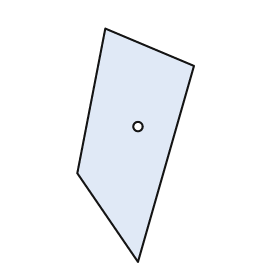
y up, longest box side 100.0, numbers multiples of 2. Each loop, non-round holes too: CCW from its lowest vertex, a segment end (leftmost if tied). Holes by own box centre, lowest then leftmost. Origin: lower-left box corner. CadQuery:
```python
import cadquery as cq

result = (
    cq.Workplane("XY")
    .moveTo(26.0, 0.0)
    .lineTo(50.0, 84.0)
    .lineTo(12.0, 100.0)
    .lineTo(0.0, 38.0)
    .close()
    .moveTo(26.0, 58.0)
    .circle(2.0)
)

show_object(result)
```